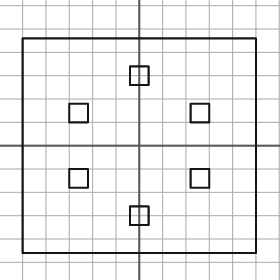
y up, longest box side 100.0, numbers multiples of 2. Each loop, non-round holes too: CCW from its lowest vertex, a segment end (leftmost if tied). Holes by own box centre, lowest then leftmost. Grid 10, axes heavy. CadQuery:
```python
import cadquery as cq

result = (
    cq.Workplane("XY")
    .moveTo(-50.0, -46.0)
    .lineTo(50.0, -46.0)
    .lineTo(50.0, 46.0)
    .lineTo(-50.0, 46.0)
    .close()
    .moveTo(-4.0, -34.0)
    .lineTo(4.0, -34.0)
    .lineTo(4.0, -26.0)
    .lineTo(-4.0, -26.0)
    .close()
    .moveTo(-30.0, -18.0)
    .lineTo(-22.0, -18.0)
    .lineTo(-22.0, -10.0)
    .lineTo(-30.0, -10.0)
    .close()
    .moveTo(22.0, -18.0)
    .lineTo(30.0, -18.0)
    .lineTo(30.0, -10.0)
    .lineTo(22.0, -10.0)
    .close()
    .moveTo(-30.0, 10.0)
    .lineTo(-22.0, 10.0)
    .lineTo(-22.0, 18.0)
    .lineTo(-30.0, 18.0)
    .close()
    .moveTo(22.0, 10.0)
    .lineTo(30.0, 10.0)
    .lineTo(30.0, 18.0)
    .lineTo(22.0, 18.0)
    .close()
    .moveTo(-4.0, 26.0)
    .lineTo(4.0, 26.0)
    .lineTo(4.0, 34.0)
    .lineTo(-4.0, 34.0)
    .close()
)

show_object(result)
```